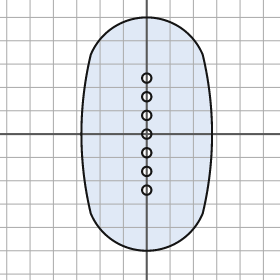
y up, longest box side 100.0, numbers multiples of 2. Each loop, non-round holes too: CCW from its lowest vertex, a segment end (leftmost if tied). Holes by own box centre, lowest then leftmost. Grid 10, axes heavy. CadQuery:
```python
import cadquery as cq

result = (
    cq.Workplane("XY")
    .moveTo(-24.0, -34.0)
    .threePointArc((0.0, -50.0), (24.0, -34.0))
    .threePointArc((28.0, 0.0), (24.0, 34.0))
    .threePointArc((0.0, 50.0), (-24.0, 34.0))
    .threePointArc((-28.0, 0.0), (-24.0, -34.0))
    .close()
    .moveTo(0.0, -24.0)
    .circle(2.0)
    .moveTo(0.0, -16.0)
    .circle(2.0)
    .moveTo(0.0, -8.0)
    .circle(2.0)
    .moveTo(0.0, 0.0)
    .circle(2.0)
    .moveTo(0.0, 8.0)
    .circle(2.0)
    .moveTo(0.0, 16.0)
    .circle(2.0)
    .moveTo(0.0, 24.0)
    .circle(2.0)
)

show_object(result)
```